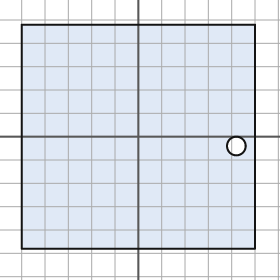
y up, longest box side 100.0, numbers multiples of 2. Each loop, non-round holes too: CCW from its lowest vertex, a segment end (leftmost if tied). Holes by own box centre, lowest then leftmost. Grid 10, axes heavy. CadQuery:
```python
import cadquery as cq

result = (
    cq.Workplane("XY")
    .moveTo(-50.0, -48.0)
    .lineTo(50.0, -48.0)
    .lineTo(50.0, 48.0)
    .lineTo(-50.0, 48.0)
    .close()
    .moveTo(42.0, -4.0)
    .circle(4.0)
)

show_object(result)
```